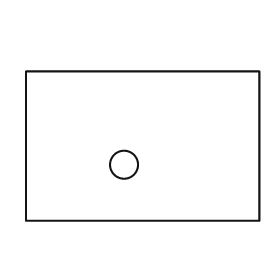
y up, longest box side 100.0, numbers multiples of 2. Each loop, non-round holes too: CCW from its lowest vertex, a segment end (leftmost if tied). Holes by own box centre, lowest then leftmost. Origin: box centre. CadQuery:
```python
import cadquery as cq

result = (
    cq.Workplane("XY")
    .moveTo(-50.0, -32.0)
    .lineTo(50.0, -32.0)
    .lineTo(50.0, 32.0)
    .lineTo(-50.0, 32.0)
    .close()
    .moveTo(-8.0, -8.0)
    .circle(6.0)
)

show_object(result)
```